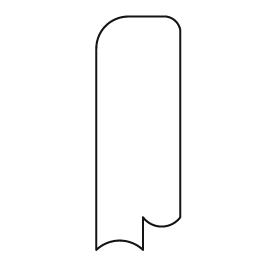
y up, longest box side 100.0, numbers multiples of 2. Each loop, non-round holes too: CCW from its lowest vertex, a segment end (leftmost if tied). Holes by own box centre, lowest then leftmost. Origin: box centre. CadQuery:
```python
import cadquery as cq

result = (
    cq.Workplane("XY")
    .moveTo(-18.0, -50.0)
    .threePointArc((-8.0, -46.0), (2.0, -50.0))
    .lineTo(2.0, -36.0)
    .threePointArc((10.0, -40.0), (18.0, -36.0))
    .lineTo(18.0, 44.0)
    .threePointArc((16.0, 48.0), (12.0, 50.0))
    .lineTo(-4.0, 50.0)
    .threePointArc((-14.0, 46.0), (-18.0, 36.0))
    .close()
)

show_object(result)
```